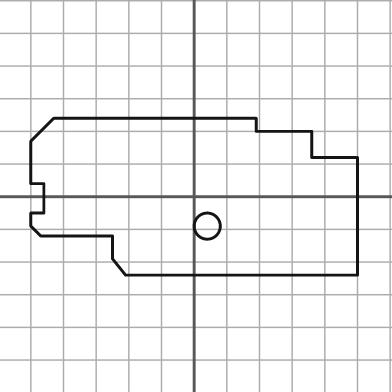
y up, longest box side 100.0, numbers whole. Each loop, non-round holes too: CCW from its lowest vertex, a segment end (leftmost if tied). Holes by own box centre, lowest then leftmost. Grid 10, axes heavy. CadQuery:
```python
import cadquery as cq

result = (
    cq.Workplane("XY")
    .moveTo(-21.0, -24.0)
    .lineTo(50.0, -24.0)
    .lineTo(50.0, 12.0)
    .lineTo(36.0, 12.0)
    .lineTo(36.0, 20.0)
    .lineTo(19.0, 20.0)
    .lineTo(19.0, 24.0)
    .lineTo(-43.0, 24.0)
    .lineTo(-50.0, 17.0)
    .lineTo(-50.0, 4.0)
    .lineTo(-46.0, 4.0)
    .lineTo(-46.0, -5.0)
    .lineTo(-50.0, -5.0)
    .lineTo(-50.0, -9.0)
    .lineTo(-47.0, -12.0)
    .lineTo(-25.0, -12.0)
    .lineTo(-25.0, -19.0)
    .close()
    .moveTo(4.0, -9.0)
    .circle(4.0)
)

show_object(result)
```